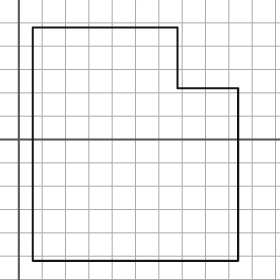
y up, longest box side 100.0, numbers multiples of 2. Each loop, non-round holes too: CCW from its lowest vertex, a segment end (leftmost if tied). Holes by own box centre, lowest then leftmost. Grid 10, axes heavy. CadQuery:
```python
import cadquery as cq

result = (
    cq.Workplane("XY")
    .moveTo(6.0, -52.0)
    .lineTo(94.0, -52.0)
    .lineTo(94.0, 22.0)
    .lineTo(68.0, 22.0)
    .lineTo(68.0, 48.0)
    .lineTo(6.0, 48.0)
    .close()
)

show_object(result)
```